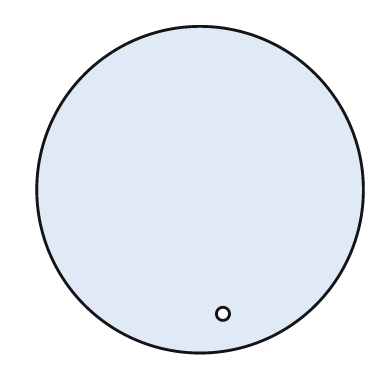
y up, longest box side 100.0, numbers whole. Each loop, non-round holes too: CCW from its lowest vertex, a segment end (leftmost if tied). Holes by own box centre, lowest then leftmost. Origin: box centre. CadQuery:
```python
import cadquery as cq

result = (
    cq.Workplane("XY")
    .moveTo(0.0, 0.0)
    .circle(50.0)
    .moveTo(7.0, -38.0)
    .circle(2.0)
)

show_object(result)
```